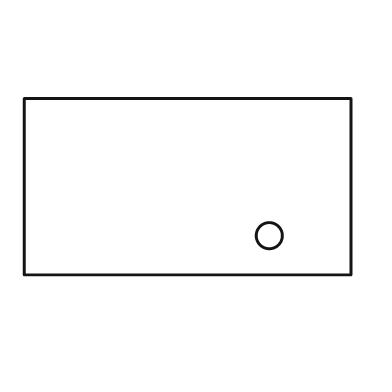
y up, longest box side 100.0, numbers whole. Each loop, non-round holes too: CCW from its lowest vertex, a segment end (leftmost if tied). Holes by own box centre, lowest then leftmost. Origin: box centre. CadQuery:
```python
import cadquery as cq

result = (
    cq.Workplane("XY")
    .moveTo(-50.0, -27.0)
    .lineTo(50.0, -27.0)
    .lineTo(50.0, 27.0)
    .lineTo(-50.0, 27.0)
    .close()
    .moveTo(25.0, -15.0)
    .circle(4.0)
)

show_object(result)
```